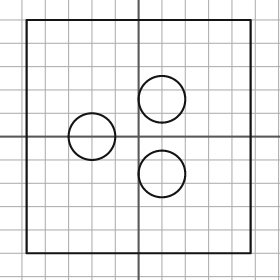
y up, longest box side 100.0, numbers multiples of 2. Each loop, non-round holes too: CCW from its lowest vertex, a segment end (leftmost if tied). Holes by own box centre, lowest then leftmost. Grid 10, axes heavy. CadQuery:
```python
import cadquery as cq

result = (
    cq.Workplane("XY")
    .moveTo(-48.0, -50.0)
    .lineTo(48.0, -50.0)
    .lineTo(48.0, 50.0)
    .lineTo(-48.0, 50.0)
    .close()
    .moveTo(10.0, -16.0)
    .circle(10.0)
    .moveTo(-20.0, 0.0)
    .circle(10.0)
    .moveTo(10.0, 16.0)
    .circle(10.0)
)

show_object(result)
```